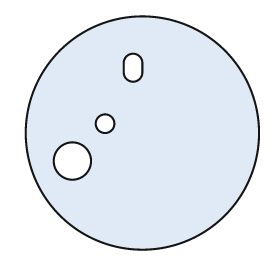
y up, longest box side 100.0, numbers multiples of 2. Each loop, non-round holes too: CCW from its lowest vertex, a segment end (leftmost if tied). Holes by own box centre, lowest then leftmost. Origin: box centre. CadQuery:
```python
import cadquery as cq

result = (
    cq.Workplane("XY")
    .moveTo(0.0, 0.0)
    .circle(50.0)
    .moveTo(-30.0, -12.0)
    .circle(8.0)
    .moveTo(-16.0, 4.0)
    .circle(4.0)
    .moveTo(-8.0, 26.0)
    .threePointArc((-4.0, 22.0), (0.0, 26.0))
    .lineTo(0.0, 30.0)
    .threePointArc((-4.0, 34.0), (-8.0, 30.0))
    .close()
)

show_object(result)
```